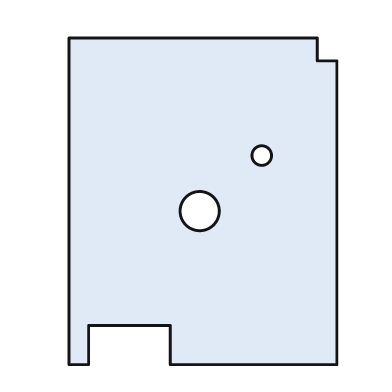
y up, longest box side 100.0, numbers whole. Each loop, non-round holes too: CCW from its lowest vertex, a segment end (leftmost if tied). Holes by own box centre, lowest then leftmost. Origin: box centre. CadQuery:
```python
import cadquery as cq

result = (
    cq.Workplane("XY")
    .moveTo(-41.0, -50.0)
    .lineTo(-35.0, -50.0)
    .lineTo(-35.0, -38.0)
    .lineTo(-10.0, -38.0)
    .lineTo(-10.0, -50.0)
    .lineTo(41.0, -50.0)
    .lineTo(41.0, 43.0)
    .lineTo(35.0, 43.0)
    .lineTo(35.0, 50.0)
    .lineTo(-41.0, 50.0)
    .close()
    .moveTo(-1.0, -3.0)
    .circle(6.0)
    .moveTo(18.0, 14.0)
    .circle(3.0)
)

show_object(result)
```